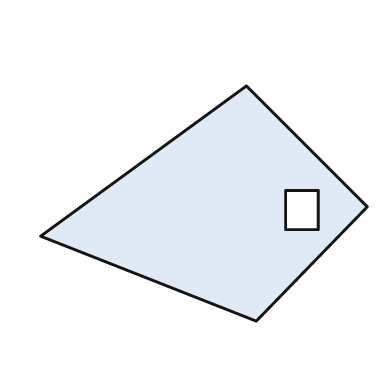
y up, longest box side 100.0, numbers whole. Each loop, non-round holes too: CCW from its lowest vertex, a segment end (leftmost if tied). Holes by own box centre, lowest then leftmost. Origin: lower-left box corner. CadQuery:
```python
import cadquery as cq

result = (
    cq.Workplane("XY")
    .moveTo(66.0, 0.0)
    .lineTo(100.0, 35.0)
    .lineTo(63.0, 72.0)
    .lineTo(0.0, 26.0)
    .close()
    .moveTo(75.0, 28.0)
    .lineTo(85.0, 28.0)
    .lineTo(85.0, 40.0)
    .lineTo(75.0, 40.0)
    .close()
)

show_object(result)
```